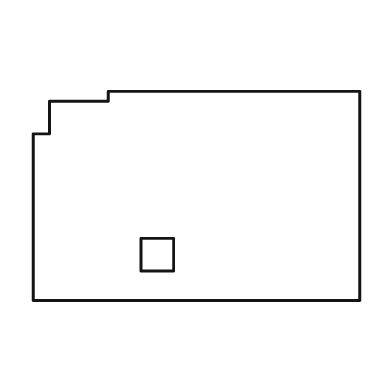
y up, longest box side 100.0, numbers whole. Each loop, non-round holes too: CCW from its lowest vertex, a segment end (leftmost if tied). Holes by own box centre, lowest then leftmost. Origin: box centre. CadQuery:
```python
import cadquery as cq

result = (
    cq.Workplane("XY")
    .moveTo(-50.0, -32.0)
    .lineTo(50.0, -32.0)
    .lineTo(50.0, 32.0)
    .lineTo(-27.0, 32.0)
    .lineTo(-27.0, 29.0)
    .lineTo(-45.0, 29.0)
    .lineTo(-45.0, 19.0)
    .lineTo(-50.0, 19.0)
    .close()
    .moveTo(-17.0, -23.0)
    .lineTo(-7.0, -23.0)
    .lineTo(-7.0, -13.0)
    .lineTo(-17.0, -13.0)
    .close()
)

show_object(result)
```